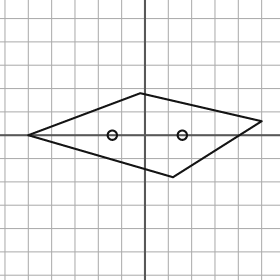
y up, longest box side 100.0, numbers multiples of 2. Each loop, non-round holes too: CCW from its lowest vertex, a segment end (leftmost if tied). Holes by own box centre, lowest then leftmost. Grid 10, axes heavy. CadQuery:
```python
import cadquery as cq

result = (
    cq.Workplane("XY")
    .moveTo(12.0, -18.0)
    .lineTo(50.0, 6.0)
    .lineTo(-2.0, 18.0)
    .lineTo(-50.0, 0.0)
    .close()
    .moveTo(-14.0, 0.0)
    .circle(2.0)
    .moveTo(16.0, 0.0)
    .circle(2.0)
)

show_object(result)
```